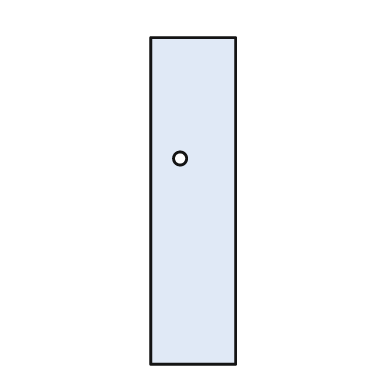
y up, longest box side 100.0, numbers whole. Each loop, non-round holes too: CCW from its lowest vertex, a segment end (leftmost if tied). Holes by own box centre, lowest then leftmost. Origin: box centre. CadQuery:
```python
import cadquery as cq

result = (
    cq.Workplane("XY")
    .moveTo(-13.0, -50.0)
    .lineTo(13.0, -50.0)
    .lineTo(13.0, 50.0)
    .lineTo(-13.0, 50.0)
    .close()
    .moveTo(-4.0, 13.0)
    .circle(2.0)
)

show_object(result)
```